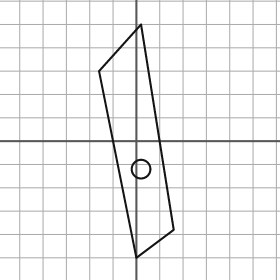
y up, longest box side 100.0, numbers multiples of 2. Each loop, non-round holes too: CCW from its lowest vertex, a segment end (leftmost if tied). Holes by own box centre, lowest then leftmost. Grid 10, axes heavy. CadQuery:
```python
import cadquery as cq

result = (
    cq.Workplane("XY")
    .moveTo(0.0, -50.0)
    .lineTo(16.0, -38.0)
    .lineTo(2.0, 50.0)
    .lineTo(-16.0, 30.0)
    .close()
    .moveTo(2.0, -12.0)
    .circle(4.0)
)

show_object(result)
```